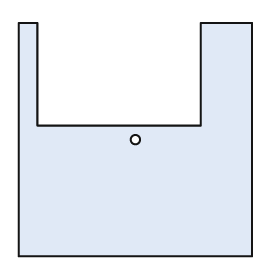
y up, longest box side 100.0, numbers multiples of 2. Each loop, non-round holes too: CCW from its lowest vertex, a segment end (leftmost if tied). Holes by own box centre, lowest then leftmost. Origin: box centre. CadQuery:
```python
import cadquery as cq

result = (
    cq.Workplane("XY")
    .moveTo(-50.0, -50.0)
    .lineTo(50.0, -50.0)
    .lineTo(50.0, 50.0)
    .lineTo(28.0, 50.0)
    .lineTo(28.0, 6.0)
    .lineTo(-42.0, 6.0)
    .lineTo(-42.0, 50.0)
    .lineTo(-50.0, 50.0)
    .close()
    .moveTo(0.0, 0.0)
    .circle(2.0)
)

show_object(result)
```